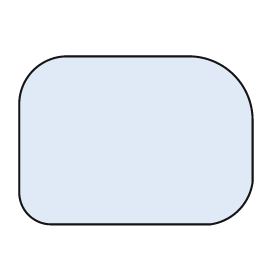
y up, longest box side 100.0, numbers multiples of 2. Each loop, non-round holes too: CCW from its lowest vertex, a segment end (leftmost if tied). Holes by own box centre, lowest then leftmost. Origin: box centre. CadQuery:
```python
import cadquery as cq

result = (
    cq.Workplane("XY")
    .moveTo(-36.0, -36.0)
    .lineTo(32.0, -36.0)
    .threePointArc((44.0, -30.0), (50.0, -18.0))
    .lineTo(50.0, 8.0)
    .threePointArc((42.0, 28.0), (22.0, 36.0))
    .lineTo(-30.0, 36.0)
    .threePointArc((-44.0, 30.0), (-50.0, 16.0))
    .lineTo(-50.0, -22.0)
    .threePointArc((-46.0, -32.0), (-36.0, -36.0))
    .close()
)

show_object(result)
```